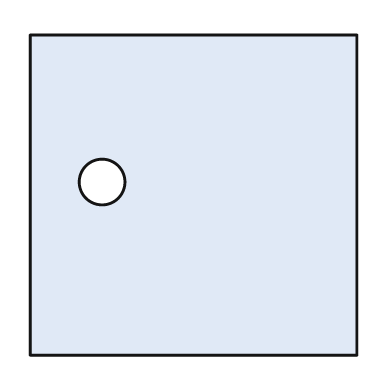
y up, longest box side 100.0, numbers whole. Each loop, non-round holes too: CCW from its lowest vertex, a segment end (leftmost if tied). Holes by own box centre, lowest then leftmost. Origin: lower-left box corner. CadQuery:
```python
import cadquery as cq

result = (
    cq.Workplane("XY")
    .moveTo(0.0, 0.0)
    .lineTo(100.0, 0.0)
    .lineTo(100.0, 98.0)
    .lineTo(0.0, 98.0)
    .close()
    .moveTo(22.0, 53.0)
    .circle(7.0)
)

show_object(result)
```